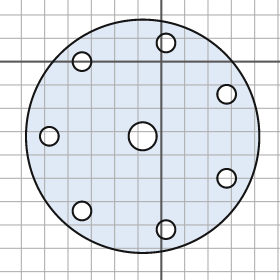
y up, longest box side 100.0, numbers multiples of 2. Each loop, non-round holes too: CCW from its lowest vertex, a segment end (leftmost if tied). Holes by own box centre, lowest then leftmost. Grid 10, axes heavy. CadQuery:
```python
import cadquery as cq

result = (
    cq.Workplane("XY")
    .moveTo(-8.0, -32.0)
    .circle(50.0)
    .moveTo(2.0, -72.0)
    .circle(4.0)
    .moveTo(-34.0, -64.0)
    .circle(4.0)
    .moveTo(28.0, -50.0)
    .circle(4.0)
    .moveTo(-48.0, -32.0)
    .circle(4.0)
    .moveTo(-8.0, -32.0)
    .circle(6.0)
    .moveTo(28.0, -14.0)
    .circle(4.0)
    .moveTo(-34.0, 0.0)
    .circle(4.0)
    .moveTo(2.0, 8.0)
    .circle(4.0)
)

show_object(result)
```